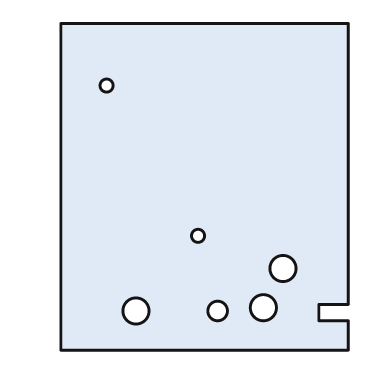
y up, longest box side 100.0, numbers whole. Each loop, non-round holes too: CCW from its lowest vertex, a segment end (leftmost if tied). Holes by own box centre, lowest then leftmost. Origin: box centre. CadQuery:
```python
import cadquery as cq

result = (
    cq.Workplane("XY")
    .moveTo(-44.0, -50.0)
    .lineTo(44.0, -50.0)
    .lineTo(44.0, -41.0)
    .lineTo(35.0, -41.0)
    .lineTo(35.0, -36.0)
    .lineTo(44.0, -36.0)
    .lineTo(44.0, 50.0)
    .lineTo(-44.0, 50.0)
    .close()
    .moveTo(-21.0, -38.0)
    .circle(4.0)
    .moveTo(4.0, -38.0)
    .circle(3.0)
    .moveTo(18.0, -37.0)
    .circle(4.0)
    .moveTo(24.0, -25.0)
    .circle(4.0)
    .moveTo(-2.0, -15.0)
    .circle(2.0)
    .moveTo(-30.0, 31.0)
    .circle(2.0)
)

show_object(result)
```